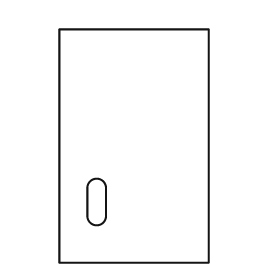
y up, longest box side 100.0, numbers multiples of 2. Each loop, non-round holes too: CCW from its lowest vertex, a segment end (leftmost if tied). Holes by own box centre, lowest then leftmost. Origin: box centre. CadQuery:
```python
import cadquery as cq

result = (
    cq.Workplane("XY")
    .moveTo(-32.0, -50.0)
    .lineTo(32.0, -50.0)
    .lineTo(32.0, 50.0)
    .lineTo(-32.0, 50.0)
    .close()
    .moveTo(-20.0, -30.0)
    .threePointArc((-16.0, -34.0), (-12.0, -30.0))
    .lineTo(-12.0, -18.0)
    .threePointArc((-16.0, -14.0), (-20.0, -18.0))
    .close()
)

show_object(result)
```